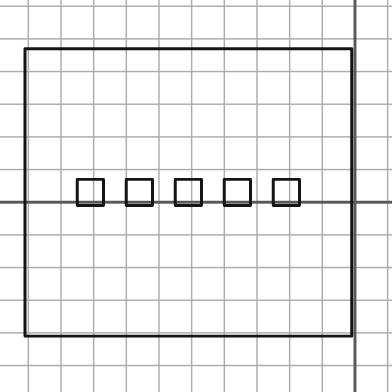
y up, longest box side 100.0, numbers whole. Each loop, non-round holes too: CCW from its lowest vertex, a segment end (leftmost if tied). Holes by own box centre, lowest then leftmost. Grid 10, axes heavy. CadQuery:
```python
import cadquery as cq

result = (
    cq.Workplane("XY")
    .moveTo(-101.0, -41.0)
    .lineTo(-1.0, -41.0)
    .lineTo(-1.0, 47.0)
    .lineTo(-101.0, 47.0)
    .close()
    .moveTo(-85.0, -1.0)
    .lineTo(-77.0, -1.0)
    .lineTo(-77.0, 7.0)
    .lineTo(-85.0, 7.0)
    .close()
    .moveTo(-70.0, -1.0)
    .lineTo(-62.0, -1.0)
    .lineTo(-62.0, 7.0)
    .lineTo(-70.0, 7.0)
    .close()
    .moveTo(-55.0, -1.0)
    .lineTo(-47.0, -1.0)
    .lineTo(-47.0, 7.0)
    .lineTo(-55.0, 7.0)
    .close()
    .moveTo(-40.0, -1.0)
    .lineTo(-32.0, -1.0)
    .lineTo(-32.0, 7.0)
    .lineTo(-40.0, 7.0)
    .close()
    .moveTo(-25.0, -1.0)
    .lineTo(-17.0, -1.0)
    .lineTo(-17.0, 7.0)
    .lineTo(-25.0, 7.0)
    .close()
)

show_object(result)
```